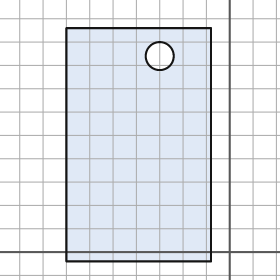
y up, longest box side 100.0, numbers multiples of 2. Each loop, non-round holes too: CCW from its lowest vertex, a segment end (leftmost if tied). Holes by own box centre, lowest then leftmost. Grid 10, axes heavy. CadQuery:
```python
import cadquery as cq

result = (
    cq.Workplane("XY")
    .moveTo(-70.0, -4.0)
    .lineTo(-8.0, -4.0)
    .lineTo(-8.0, 96.0)
    .lineTo(-70.0, 96.0)
    .close()
    .moveTo(-30.0, 84.0)
    .circle(6.0)
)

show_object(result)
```